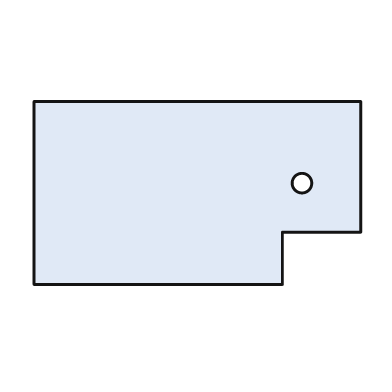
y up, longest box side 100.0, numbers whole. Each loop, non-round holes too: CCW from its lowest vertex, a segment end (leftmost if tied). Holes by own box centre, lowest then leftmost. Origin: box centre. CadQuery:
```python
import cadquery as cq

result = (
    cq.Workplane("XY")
    .moveTo(-50.0, -28.0)
    .lineTo(26.0, -28.0)
    .lineTo(26.0, -12.0)
    .lineTo(50.0, -12.0)
    .lineTo(50.0, 28.0)
    .lineTo(-50.0, 28.0)
    .close()
    .moveTo(32.0, 3.0)
    .circle(3.0)
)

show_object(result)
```